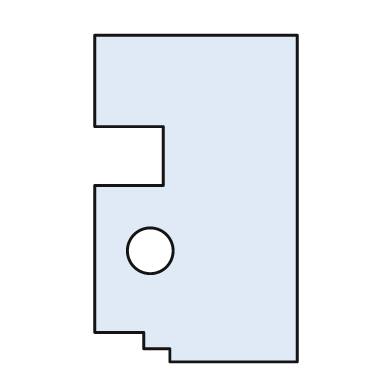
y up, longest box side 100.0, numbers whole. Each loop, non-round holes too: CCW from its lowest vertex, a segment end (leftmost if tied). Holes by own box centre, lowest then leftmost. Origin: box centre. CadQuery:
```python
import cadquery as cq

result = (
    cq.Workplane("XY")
    .moveTo(-8.0, -50.0)
    .lineTo(31.0, -50.0)
    .lineTo(31.0, 50.0)
    .lineTo(-31.0, 50.0)
    .lineTo(-31.0, 22.0)
    .lineTo(-10.0, 22.0)
    .lineTo(-10.0, 4.0)
    .lineTo(-31.0, 4.0)
    .lineTo(-31.0, -41.0)
    .lineTo(-16.0, -41.0)
    .lineTo(-16.0, -46.0)
    .lineTo(-8.0, -46.0)
    .close()
    .moveTo(-14.0, -16.0)
    .circle(7.0)
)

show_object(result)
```